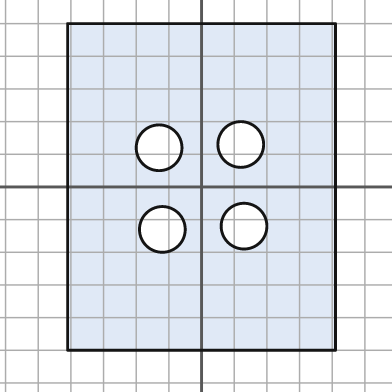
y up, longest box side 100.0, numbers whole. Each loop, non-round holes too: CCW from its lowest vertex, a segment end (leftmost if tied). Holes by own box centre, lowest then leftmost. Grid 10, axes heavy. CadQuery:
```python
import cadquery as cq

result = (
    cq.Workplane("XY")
    .moveTo(-41.0, -50.0)
    .lineTo(41.0, -50.0)
    .lineTo(41.0, 50.0)
    .lineTo(-41.0, 50.0)
    .close()
    .moveTo(-12.0, -13.0)
    .circle(7.0)
    .moveTo(13.0, -12.0)
    .circle(7.0)
    .moveTo(-13.0, 12.0)
    .circle(7.0)
    .moveTo(12.0, 13.0)
    .circle(7.0)
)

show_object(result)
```